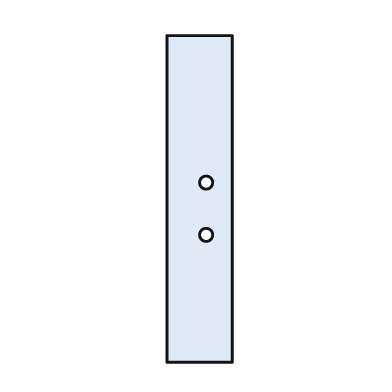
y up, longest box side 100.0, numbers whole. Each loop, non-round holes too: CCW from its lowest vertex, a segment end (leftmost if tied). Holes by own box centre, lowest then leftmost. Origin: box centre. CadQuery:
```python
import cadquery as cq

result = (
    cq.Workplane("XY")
    .moveTo(-10.0, -50.0)
    .lineTo(10.0, -50.0)
    .lineTo(10.0, 50.0)
    .lineTo(-10.0, 50.0)
    .close()
    .moveTo(2.0, -11.0)
    .circle(2.0)
    .moveTo(2.0, 5.0)
    .circle(2.0)
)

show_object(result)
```